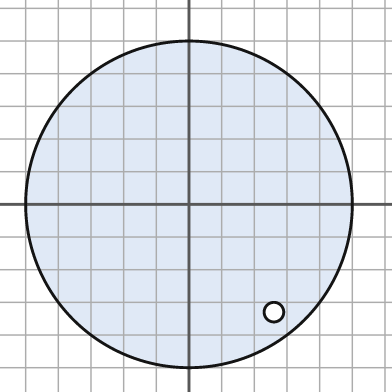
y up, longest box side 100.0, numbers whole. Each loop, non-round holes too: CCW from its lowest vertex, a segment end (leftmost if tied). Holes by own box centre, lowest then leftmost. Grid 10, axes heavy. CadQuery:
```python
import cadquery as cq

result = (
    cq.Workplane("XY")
    .moveTo(0.0, 0.0)
    .circle(50.0)
    .moveTo(26.0, -33.0)
    .circle(3.0)
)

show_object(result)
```